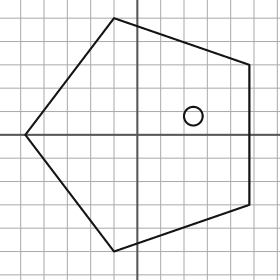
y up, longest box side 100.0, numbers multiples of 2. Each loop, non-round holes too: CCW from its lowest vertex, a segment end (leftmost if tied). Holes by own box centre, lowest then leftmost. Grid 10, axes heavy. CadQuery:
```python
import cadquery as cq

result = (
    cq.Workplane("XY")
    .moveTo(-10.0, -50.0)
    .lineTo(48.0, -30.0)
    .lineTo(48.0, 30.0)
    .lineTo(-10.0, 50.0)
    .lineTo(-48.0, 0.0)
    .close()
    .moveTo(24.0, 8.0)
    .circle(4.0)
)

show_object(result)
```